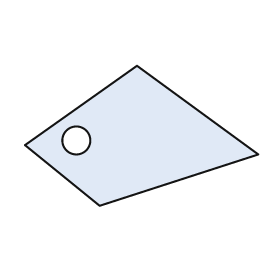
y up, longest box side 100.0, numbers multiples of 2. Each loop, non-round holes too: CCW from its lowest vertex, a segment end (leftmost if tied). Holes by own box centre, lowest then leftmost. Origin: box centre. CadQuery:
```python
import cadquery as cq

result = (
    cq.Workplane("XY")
    .moveTo(-18.0, -30.0)
    .lineTo(50.0, -8.0)
    .lineTo(-2.0, 30.0)
    .lineTo(-50.0, -4.0)
    .close()
    .moveTo(-28.0, -2.0)
    .circle(6.0)
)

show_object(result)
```